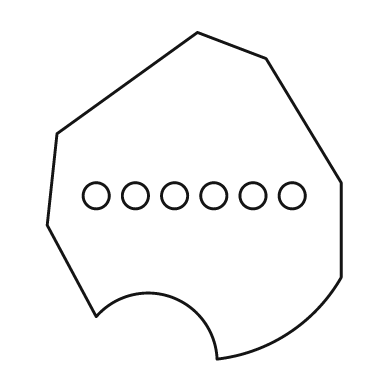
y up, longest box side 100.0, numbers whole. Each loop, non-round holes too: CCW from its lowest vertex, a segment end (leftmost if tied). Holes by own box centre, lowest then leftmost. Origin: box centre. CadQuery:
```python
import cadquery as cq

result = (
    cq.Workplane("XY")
    .moveTo(7.0, -50.0)
    .threePointArc((29.0, -42.0), (45.0, -25.0))
    .lineTo(45.0, 4.0)
    .lineTo(22.0, 42.0)
    .lineTo(1.0, 50.0)
    .lineTo(-42.0, 19.0)
    .lineTo(-45.0, -9.0)
    .lineTo(-30.0, -37.0)
    .threePointArc((-7.0, -31.0), (7.0, -50.0))
    .close()
    .moveTo(-30.0, 0.0)
    .circle(4.0)
    .moveTo(-18.0, 0.0)
    .circle(4.0)
    .moveTo(-6.0, 0.0)
    .circle(4.0)
    .moveTo(6.0, 0.0)
    .circle(4.0)
    .moveTo(18.0, 0.0)
    .circle(4.0)
    .moveTo(30.0, 0.0)
    .circle(4.0)
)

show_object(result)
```